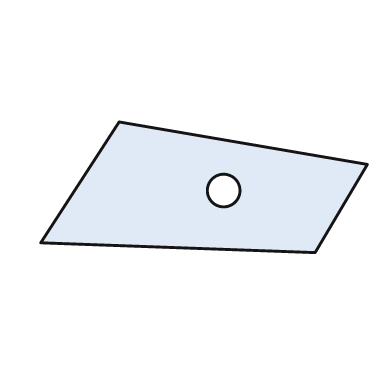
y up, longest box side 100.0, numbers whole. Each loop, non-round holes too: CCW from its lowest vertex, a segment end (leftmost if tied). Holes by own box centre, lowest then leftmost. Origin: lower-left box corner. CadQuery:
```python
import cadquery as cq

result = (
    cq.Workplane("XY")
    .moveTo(84.0, 0.0)
    .lineTo(100.0, 27.0)
    .lineTo(24.0, 40.0)
    .lineTo(0.0, 3.0)
    .close()
    .moveTo(56.0, 19.0)
    .circle(5.0)
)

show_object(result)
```